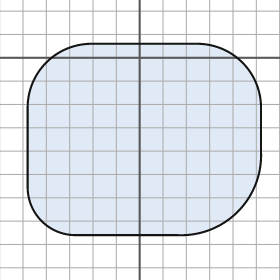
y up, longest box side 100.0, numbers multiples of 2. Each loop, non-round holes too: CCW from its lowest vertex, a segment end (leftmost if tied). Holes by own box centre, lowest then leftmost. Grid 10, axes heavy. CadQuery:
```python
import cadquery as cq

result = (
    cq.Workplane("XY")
    .moveTo(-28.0, -76.0)
    .lineTo(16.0, -76.0)
    .threePointArc((42.0, -66.0), (52.0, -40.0))
    .lineTo(52.0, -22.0)
    .threePointArc((44.0, -2.0), (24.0, 6.0))
    .lineTo(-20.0, 6.0)
    .threePointArc((-40.0, -2.0), (-48.0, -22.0))
    .lineTo(-48.0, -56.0)
    .threePointArc((-42.0, -70.0), (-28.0, -76.0))
    .close()
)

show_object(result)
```